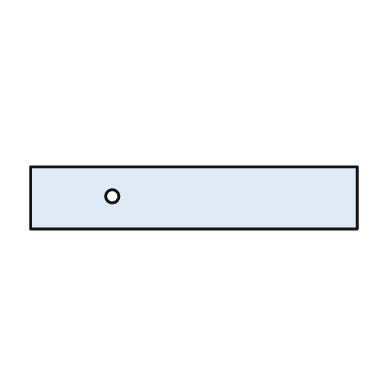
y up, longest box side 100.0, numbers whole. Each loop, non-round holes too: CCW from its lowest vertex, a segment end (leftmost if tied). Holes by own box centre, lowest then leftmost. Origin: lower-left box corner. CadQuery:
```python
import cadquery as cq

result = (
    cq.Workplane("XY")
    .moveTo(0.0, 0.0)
    .lineTo(100.0, 0.0)
    .lineTo(100.0, 19.0)
    .lineTo(0.0, 19.0)
    .close()
    .moveTo(25.0, 10.0)
    .circle(2.0)
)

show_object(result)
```